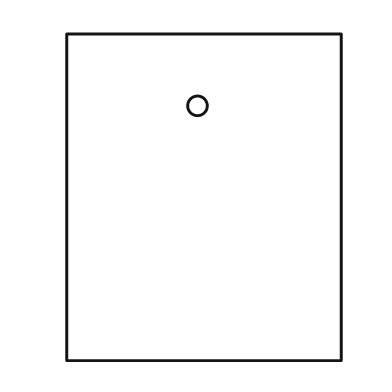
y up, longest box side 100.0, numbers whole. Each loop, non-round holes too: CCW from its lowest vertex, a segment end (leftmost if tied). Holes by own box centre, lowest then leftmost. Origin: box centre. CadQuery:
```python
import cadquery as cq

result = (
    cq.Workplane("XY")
    .moveTo(-42.0, -50.0)
    .lineTo(42.0, -50.0)
    .lineTo(42.0, 50.0)
    .lineTo(-42.0, 50.0)
    .close()
    .moveTo(-2.0, 28.0)
    .circle(3.0)
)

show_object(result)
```